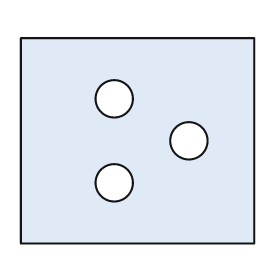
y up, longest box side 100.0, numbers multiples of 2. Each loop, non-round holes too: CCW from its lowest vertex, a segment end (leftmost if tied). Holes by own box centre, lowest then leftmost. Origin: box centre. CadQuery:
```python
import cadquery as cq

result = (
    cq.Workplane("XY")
    .moveTo(-50.0, -44.0)
    .lineTo(50.0, -44.0)
    .lineTo(50.0, 44.0)
    .lineTo(-50.0, 44.0)
    .close()
    .moveTo(-10.0, -18.0)
    .circle(8.0)
    .moveTo(22.0, 0.0)
    .circle(8.0)
    .moveTo(-10.0, 18.0)
    .circle(8.0)
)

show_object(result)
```